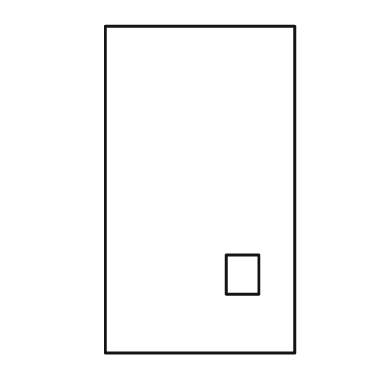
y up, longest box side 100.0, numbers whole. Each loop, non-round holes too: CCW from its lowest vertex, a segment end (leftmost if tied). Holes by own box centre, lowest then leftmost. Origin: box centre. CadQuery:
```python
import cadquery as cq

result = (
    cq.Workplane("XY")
    .moveTo(-29.0, -50.0)
    .lineTo(29.0, -50.0)
    .lineTo(29.0, 50.0)
    .lineTo(-29.0, 50.0)
    .close()
    .moveTo(8.0, -32.0)
    .lineTo(18.0, -32.0)
    .lineTo(18.0, -20.0)
    .lineTo(8.0, -20.0)
    .close()
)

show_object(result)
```